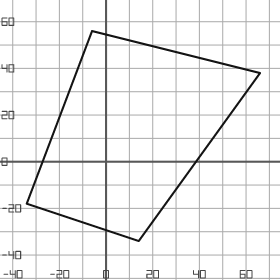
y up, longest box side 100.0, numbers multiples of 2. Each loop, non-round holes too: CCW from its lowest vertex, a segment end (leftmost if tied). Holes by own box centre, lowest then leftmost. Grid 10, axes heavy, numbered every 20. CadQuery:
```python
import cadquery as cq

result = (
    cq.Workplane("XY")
    .moveTo(14.0, -34.0)
    .lineTo(66.0, 38.0)
    .lineTo(-6.0, 56.0)
    .lineTo(-34.0, -18.0)
    .close()
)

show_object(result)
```